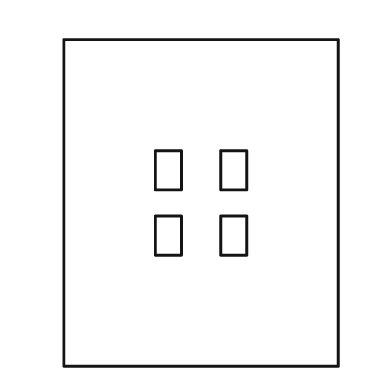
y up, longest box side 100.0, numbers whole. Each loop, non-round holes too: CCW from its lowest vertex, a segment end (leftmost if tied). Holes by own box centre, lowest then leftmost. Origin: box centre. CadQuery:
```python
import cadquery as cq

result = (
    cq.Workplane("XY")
    .moveTo(-42.0, -50.0)
    .lineTo(42.0, -50.0)
    .lineTo(42.0, 50.0)
    .lineTo(-42.0, 50.0)
    .close()
    .moveTo(-14.0, -16.0)
    .lineTo(-6.0, -16.0)
    .lineTo(-6.0, -4.0)
    .lineTo(-14.0, -4.0)
    .close()
    .moveTo(6.0, -16.0)
    .lineTo(14.0, -16.0)
    .lineTo(14.0, -4.0)
    .lineTo(6.0, -4.0)
    .close()
    .moveTo(-14.0, 4.0)
    .lineTo(-6.0, 4.0)
    .lineTo(-6.0, 16.0)
    .lineTo(-14.0, 16.0)
    .close()
    .moveTo(6.0, 4.0)
    .lineTo(14.0, 4.0)
    .lineTo(14.0, 16.0)
    .lineTo(6.0, 16.0)
    .close()
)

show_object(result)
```